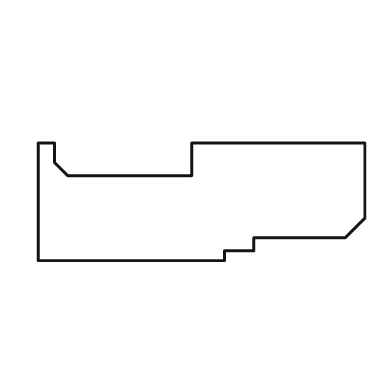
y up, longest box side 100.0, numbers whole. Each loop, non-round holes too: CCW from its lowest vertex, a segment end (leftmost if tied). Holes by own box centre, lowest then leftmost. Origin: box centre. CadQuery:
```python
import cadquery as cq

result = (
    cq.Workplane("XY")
    .moveTo(-50.0, -18.0)
    .lineTo(7.0, -18.0)
    .lineTo(7.0, -15.0)
    .lineTo(16.0, -15.0)
    .lineTo(16.0, -11.0)
    .lineTo(44.0, -11.0)
    .lineTo(50.0, -5.0)
    .lineTo(50.0, 18.0)
    .lineTo(-3.0, 18.0)
    .lineTo(-3.0, 8.0)
    .lineTo(-41.0, 8.0)
    .lineTo(-45.0, 12.0)
    .lineTo(-45.0, 18.0)
    .lineTo(-50.0, 18.0)
    .close()
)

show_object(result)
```